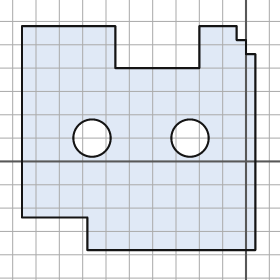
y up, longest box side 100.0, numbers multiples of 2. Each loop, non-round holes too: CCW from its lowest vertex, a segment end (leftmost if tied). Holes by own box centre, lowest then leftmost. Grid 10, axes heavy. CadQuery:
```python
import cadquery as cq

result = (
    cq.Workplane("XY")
    .moveTo(-68.0, -38.0)
    .lineTo(4.0, -38.0)
    .lineTo(4.0, 46.0)
    .lineTo(0.0, 46.0)
    .lineTo(0.0, 52.0)
    .lineTo(-4.0, 52.0)
    .lineTo(-4.0, 58.0)
    .lineTo(-20.0, 58.0)
    .lineTo(-20.0, 40.0)
    .lineTo(-56.0, 40.0)
    .lineTo(-56.0, 58.0)
    .lineTo(-96.0, 58.0)
    .lineTo(-96.0, -24.0)
    .lineTo(-68.0, -24.0)
    .close()
    .moveTo(-66.0, 10.0)
    .circle(8.0)
    .moveTo(-24.0, 10.0)
    .circle(8.0)
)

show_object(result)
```